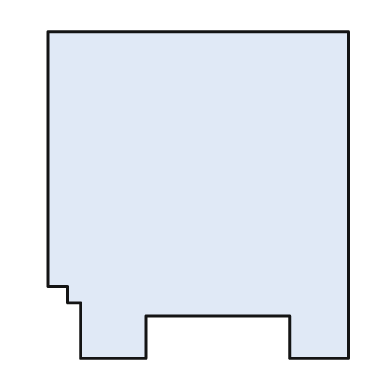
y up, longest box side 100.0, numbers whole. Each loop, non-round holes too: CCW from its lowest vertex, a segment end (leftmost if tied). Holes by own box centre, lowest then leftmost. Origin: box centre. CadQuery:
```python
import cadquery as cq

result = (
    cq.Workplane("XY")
    .moveTo(-36.0, -50.0)
    .lineTo(-16.0, -50.0)
    .lineTo(-16.0, -37.0)
    .lineTo(28.0, -37.0)
    .lineTo(28.0, -50.0)
    .lineTo(46.0, -50.0)
    .lineTo(46.0, 50.0)
    .lineTo(-46.0, 50.0)
    .lineTo(-46.0, -28.0)
    .lineTo(-40.0, -28.0)
    .lineTo(-40.0, -33.0)
    .lineTo(-36.0, -33.0)
    .close()
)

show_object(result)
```